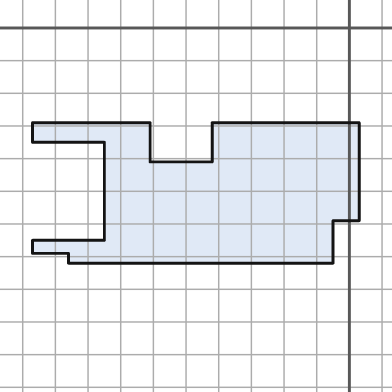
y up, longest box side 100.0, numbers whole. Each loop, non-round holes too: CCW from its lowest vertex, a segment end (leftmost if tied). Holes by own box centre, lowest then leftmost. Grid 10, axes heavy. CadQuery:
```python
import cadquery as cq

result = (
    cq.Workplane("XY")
    .moveTo(-86.0, -72.0)
    .lineTo(-5.0, -72.0)
    .lineTo(-5.0, -59.0)
    .lineTo(3.0, -59.0)
    .lineTo(3.0, -29.0)
    .lineTo(-42.0, -29.0)
    .lineTo(-42.0, -41.0)
    .lineTo(-61.0, -41.0)
    .lineTo(-61.0, -29.0)
    .lineTo(-97.0, -29.0)
    .lineTo(-97.0, -35.0)
    .lineTo(-75.0, -35.0)
    .lineTo(-75.0, -65.0)
    .lineTo(-97.0, -65.0)
    .lineTo(-97.0, -69.0)
    .lineTo(-86.0, -69.0)
    .close()
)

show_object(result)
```